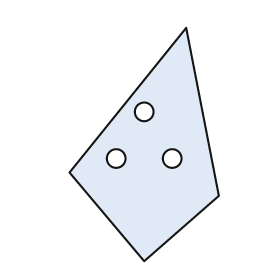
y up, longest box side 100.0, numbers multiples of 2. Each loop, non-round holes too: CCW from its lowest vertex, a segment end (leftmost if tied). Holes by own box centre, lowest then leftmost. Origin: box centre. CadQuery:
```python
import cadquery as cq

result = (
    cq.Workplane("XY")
    .moveTo(0.0, -50.0)
    .lineTo(32.0, -22.0)
    .lineTo(18.0, 50.0)
    .lineTo(-32.0, -12.0)
    .close()
    .moveTo(-12.0, -6.0)
    .circle(4.0)
    .moveTo(12.0, -6.0)
    .circle(4.0)
    .moveTo(0.0, 14.0)
    .circle(4.0)
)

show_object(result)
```